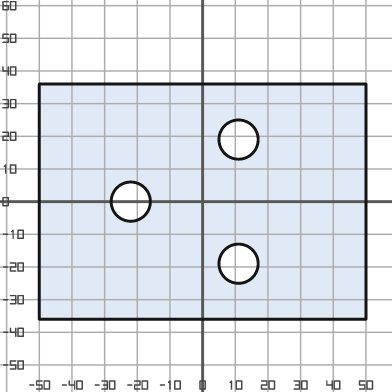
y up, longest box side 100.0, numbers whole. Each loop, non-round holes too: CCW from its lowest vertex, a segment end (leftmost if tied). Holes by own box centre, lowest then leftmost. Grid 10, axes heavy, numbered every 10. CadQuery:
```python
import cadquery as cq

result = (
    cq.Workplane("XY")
    .moveTo(-50.0, -36.0)
    .lineTo(50.0, -36.0)
    .lineTo(50.0, 36.0)
    .lineTo(-50.0, 36.0)
    .close()
    .moveTo(11.0, -19.0)
    .circle(6.0)
    .moveTo(-22.0, 0.0)
    .circle(6.0)
    .moveTo(11.0, 19.0)
    .circle(6.0)
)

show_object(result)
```